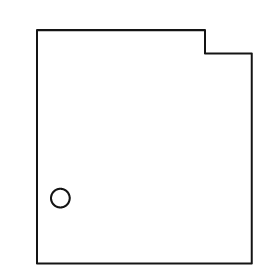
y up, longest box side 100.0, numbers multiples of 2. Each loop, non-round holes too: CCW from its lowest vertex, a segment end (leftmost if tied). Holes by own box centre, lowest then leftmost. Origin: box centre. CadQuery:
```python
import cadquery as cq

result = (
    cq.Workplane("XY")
    .moveTo(-46.0, -50.0)
    .lineTo(46.0, -50.0)
    .lineTo(46.0, 40.0)
    .lineTo(26.0, 40.0)
    .lineTo(26.0, 50.0)
    .lineTo(-46.0, 50.0)
    .close()
    .moveTo(-36.0, -22.0)
    .circle(4.0)
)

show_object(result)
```